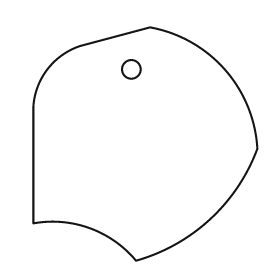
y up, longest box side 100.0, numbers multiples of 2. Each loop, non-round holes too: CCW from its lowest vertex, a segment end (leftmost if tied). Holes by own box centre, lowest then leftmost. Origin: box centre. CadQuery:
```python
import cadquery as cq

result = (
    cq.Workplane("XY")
    .moveTo(-4.0, -50.0)
    .threePointArc((28.0, -32.0), (48.0, -2.0))
    .threePointArc((34.0, 32.0), (2.0, 50.0))
    .lineTo(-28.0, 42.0)
    .threePointArc((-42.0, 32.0), (-48.0, 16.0))
    .lineTo(-48.0, -34.0)
    .threePointArc((-24.0, -36.0), (-4.0, -50.0))
    .close()
    .moveTo(-6.0, 32.0)
    .circle(4.0)
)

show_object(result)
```